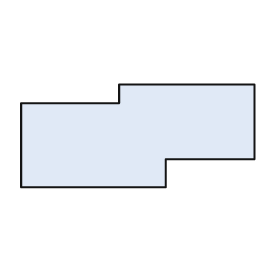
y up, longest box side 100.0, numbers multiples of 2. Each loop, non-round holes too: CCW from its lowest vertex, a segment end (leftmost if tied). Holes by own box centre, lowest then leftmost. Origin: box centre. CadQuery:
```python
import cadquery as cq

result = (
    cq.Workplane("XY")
    .moveTo(-50.0, -22.0)
    .lineTo(12.0, -22.0)
    .lineTo(12.0, -10.0)
    .lineTo(50.0, -10.0)
    .lineTo(50.0, 22.0)
    .lineTo(-8.0, 22.0)
    .lineTo(-8.0, 14.0)
    .lineTo(-50.0, 14.0)
    .close()
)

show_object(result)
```